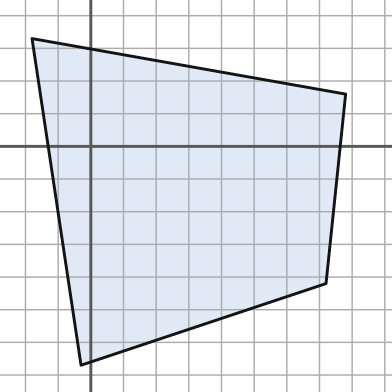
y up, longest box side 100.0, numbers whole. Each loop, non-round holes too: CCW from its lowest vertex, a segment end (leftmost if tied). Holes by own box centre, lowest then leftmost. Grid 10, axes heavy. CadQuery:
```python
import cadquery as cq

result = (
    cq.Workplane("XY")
    .moveTo(-3.0, -67.0)
    .lineTo(72.0, -42.0)
    .lineTo(78.0, 16.0)
    .lineTo(-18.0, 33.0)
    .close()
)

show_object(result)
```